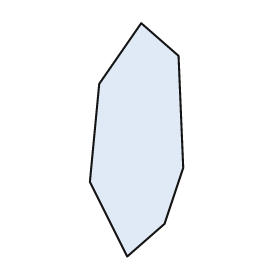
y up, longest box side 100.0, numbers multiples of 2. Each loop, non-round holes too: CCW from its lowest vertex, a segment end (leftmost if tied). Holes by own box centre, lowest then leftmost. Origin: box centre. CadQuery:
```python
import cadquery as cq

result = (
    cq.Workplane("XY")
    .moveTo(-4.0, -50.0)
    .lineTo(12.0, -36.0)
    .lineTo(20.0, -12.0)
    .lineTo(18.0, 36.0)
    .lineTo(2.0, 50.0)
    .lineTo(-16.0, 24.0)
    .lineTo(-20.0, -18.0)
    .close()
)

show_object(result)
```